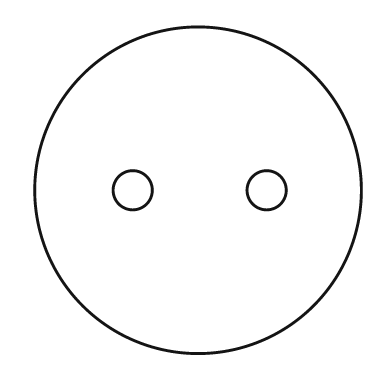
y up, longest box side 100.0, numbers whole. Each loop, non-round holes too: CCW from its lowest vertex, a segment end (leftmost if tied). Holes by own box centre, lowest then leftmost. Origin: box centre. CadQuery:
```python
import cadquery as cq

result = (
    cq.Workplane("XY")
    .moveTo(0.0, 0.0)
    .circle(50.0)
    .moveTo(-20.0, 0.0)
    .circle(6.0)
    .moveTo(21.0, 0.0)
    .circle(6.0)
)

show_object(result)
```